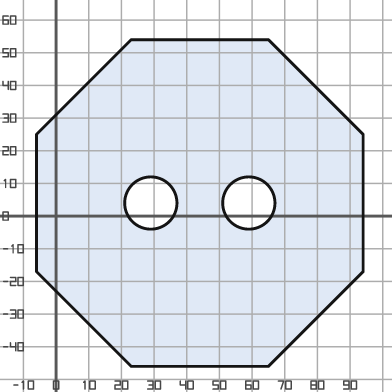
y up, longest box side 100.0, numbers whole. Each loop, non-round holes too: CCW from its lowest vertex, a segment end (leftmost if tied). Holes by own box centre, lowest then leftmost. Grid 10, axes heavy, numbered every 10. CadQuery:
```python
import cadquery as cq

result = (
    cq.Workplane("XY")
    .moveTo(23.0, -46.0)
    .lineTo(65.0, -46.0)
    .lineTo(94.0, -17.0)
    .lineTo(94.0, 25.0)
    .lineTo(65.0, 54.0)
    .lineTo(23.0, 54.0)
    .lineTo(-6.0, 25.0)
    .lineTo(-6.0, -17.0)
    .close()
    .moveTo(29.0, 4.0)
    .circle(8.0)
    .moveTo(59.0, 4.0)
    .circle(8.0)
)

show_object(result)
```